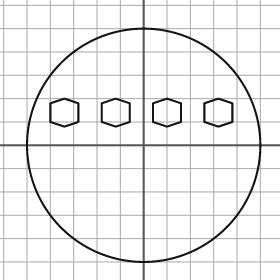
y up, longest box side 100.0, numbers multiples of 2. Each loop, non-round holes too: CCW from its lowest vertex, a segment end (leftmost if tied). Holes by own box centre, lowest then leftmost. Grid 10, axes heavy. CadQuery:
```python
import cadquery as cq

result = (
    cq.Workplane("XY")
    .moveTo(0.0, 0.0)
    .circle(50.0)
    .moveTo(-34.0, 8.0)
    .lineTo(-28.0, 10.0)
    .lineTo(-28.0, 18.0)
    .lineTo(-34.0, 20.0)
    .lineTo(-40.0, 18.0)
    .lineTo(-40.0, 10.0)
    .close()
    .moveTo(-12.0, 8.0)
    .lineTo(-6.0, 10.0)
    .lineTo(-6.0, 18.0)
    .lineTo(-12.0, 20.0)
    .lineTo(-18.0, 18.0)
    .lineTo(-18.0, 10.0)
    .close()
    .moveTo(10.0, 8.0)
    .lineTo(16.0, 10.0)
    .lineTo(16.0, 18.0)
    .lineTo(10.0, 20.0)
    .lineTo(4.0, 18.0)
    .lineTo(4.0, 10.0)
    .close()
    .moveTo(32.0, 8.0)
    .lineTo(38.0, 10.0)
    .lineTo(38.0, 18.0)
    .lineTo(32.0, 20.0)
    .lineTo(26.0, 18.0)
    .lineTo(26.0, 10.0)
    .close()
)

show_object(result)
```